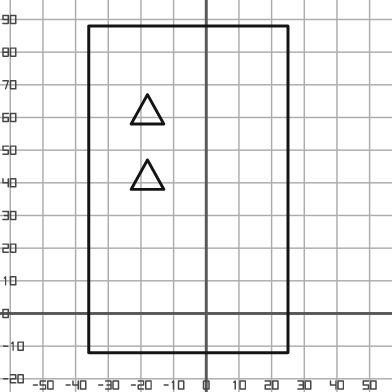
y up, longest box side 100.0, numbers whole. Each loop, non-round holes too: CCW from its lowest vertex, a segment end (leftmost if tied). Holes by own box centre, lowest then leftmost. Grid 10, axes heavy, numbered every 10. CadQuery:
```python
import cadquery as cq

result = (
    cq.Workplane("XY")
    .moveTo(-36.0, -12.0)
    .lineTo(25.0, -12.0)
    .lineTo(25.0, 88.0)
    .lineTo(-36.0, 88.0)
    .close()
    .moveTo(-23.0, 38.0)
    .lineTo(-13.0, 38.0)
    .lineTo(-18.0, 47.0)
    .close()
    .moveTo(-23.0, 58.0)
    .lineTo(-13.0, 58.0)
    .lineTo(-18.0, 67.0)
    .close()
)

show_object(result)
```